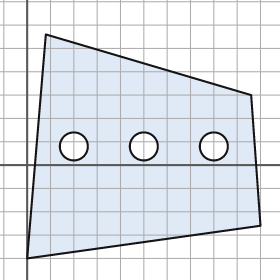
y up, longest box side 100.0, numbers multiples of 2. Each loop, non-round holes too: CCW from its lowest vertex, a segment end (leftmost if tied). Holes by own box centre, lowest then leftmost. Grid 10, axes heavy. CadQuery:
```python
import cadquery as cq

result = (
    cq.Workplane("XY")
    .moveTo(0.0, -40.0)
    .lineTo(100.0, -26.0)
    .lineTo(96.0, 30.0)
    .lineTo(8.0, 56.0)
    .close()
    .moveTo(20.0, 8.0)
    .circle(6.0)
    .moveTo(50.0, 8.0)
    .circle(6.0)
    .moveTo(80.0, 8.0)
    .circle(6.0)
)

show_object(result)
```